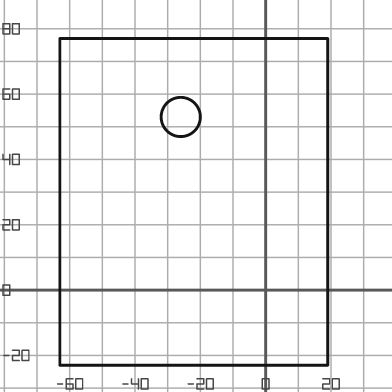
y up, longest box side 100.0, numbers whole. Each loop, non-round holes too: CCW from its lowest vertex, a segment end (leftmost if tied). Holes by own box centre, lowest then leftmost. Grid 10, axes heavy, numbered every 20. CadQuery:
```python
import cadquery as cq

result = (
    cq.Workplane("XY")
    .moveTo(-63.0, -23.0)
    .lineTo(19.0, -23.0)
    .lineTo(19.0, 77.0)
    .lineTo(-63.0, 77.0)
    .close()
    .moveTo(-26.0, 53.0)
    .circle(6.0)
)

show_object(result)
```